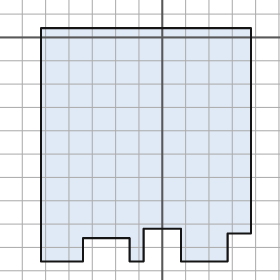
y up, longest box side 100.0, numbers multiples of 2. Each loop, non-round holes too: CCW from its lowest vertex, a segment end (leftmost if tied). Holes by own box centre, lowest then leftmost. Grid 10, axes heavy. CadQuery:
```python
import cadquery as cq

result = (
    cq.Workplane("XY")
    .moveTo(-52.0, -96.0)
    .lineTo(-34.0, -96.0)
    .lineTo(-34.0, -86.0)
    .lineTo(-14.0, -86.0)
    .lineTo(-14.0, -96.0)
    .lineTo(-8.0, -96.0)
    .lineTo(-8.0, -82.0)
    .lineTo(8.0, -82.0)
    .lineTo(8.0, -96.0)
    .lineTo(28.0, -96.0)
    .lineTo(28.0, -84.0)
    .lineTo(38.0, -84.0)
    .lineTo(38.0, 4.0)
    .lineTo(-52.0, 4.0)
    .close()
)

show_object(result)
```